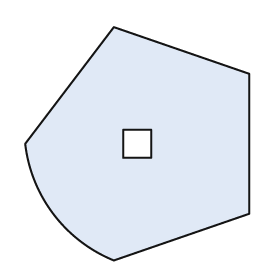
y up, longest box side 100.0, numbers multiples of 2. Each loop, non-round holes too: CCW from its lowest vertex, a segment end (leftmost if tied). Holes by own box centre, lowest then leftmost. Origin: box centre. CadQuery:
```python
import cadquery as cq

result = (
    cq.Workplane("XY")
    .moveTo(-10.0, -50.0)
    .lineTo(48.0, -30.0)
    .lineTo(48.0, 30.0)
    .lineTo(-10.0, 50.0)
    .lineTo(-48.0, 0.0)
    .threePointArc((-36.0, -30.0), (-10.0, -50.0))
    .close()
    .moveTo(-6.0, -6.0)
    .lineTo(6.0, -6.0)
    .lineTo(6.0, 6.0)
    .lineTo(-6.0, 6.0)
    .close()
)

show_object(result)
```